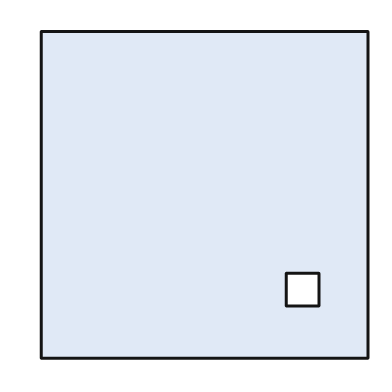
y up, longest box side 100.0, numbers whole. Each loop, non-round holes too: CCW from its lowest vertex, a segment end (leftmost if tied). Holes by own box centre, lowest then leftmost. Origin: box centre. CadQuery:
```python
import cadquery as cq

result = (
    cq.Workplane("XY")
    .moveTo(-50.0, -50.0)
    .lineTo(50.0, -50.0)
    .lineTo(50.0, 50.0)
    .lineTo(-50.0, 50.0)
    .close()
    .moveTo(25.0, -34.0)
    .lineTo(35.0, -34.0)
    .lineTo(35.0, -24.0)
    .lineTo(25.0, -24.0)
    .close()
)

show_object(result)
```